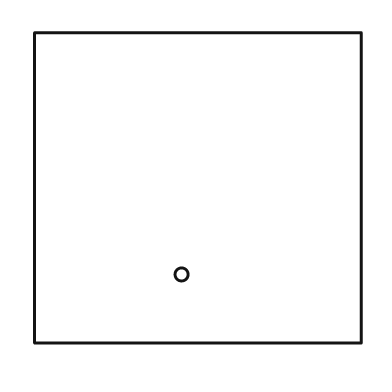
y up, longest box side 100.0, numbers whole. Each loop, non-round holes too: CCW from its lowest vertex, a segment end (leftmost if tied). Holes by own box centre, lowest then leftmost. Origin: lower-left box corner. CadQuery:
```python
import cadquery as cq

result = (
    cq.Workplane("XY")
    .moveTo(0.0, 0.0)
    .lineTo(100.0, 0.0)
    .lineTo(100.0, 95.0)
    .lineTo(0.0, 95.0)
    .close()
    .moveTo(45.0, 21.0)
    .circle(2.0)
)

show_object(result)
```